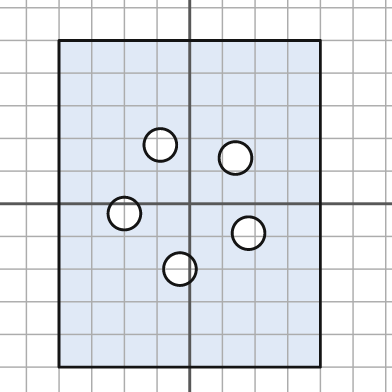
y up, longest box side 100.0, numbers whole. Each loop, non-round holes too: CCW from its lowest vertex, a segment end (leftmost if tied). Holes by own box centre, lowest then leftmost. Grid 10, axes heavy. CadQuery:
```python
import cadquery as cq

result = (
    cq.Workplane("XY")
    .moveTo(-40.0, -50.0)
    .lineTo(40.0, -50.0)
    .lineTo(40.0, 50.0)
    .lineTo(-40.0, 50.0)
    .close()
    .moveTo(-3.0, -20.0)
    .circle(5.0)
    .moveTo(18.0, -9.0)
    .circle(5.0)
    .moveTo(-20.0, -3.0)
    .circle(5.0)
    .moveTo(14.0, 14.0)
    .circle(5.0)
    .moveTo(-9.0, 18.0)
    .circle(5.0)
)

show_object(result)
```